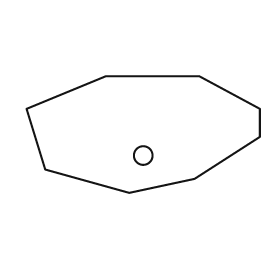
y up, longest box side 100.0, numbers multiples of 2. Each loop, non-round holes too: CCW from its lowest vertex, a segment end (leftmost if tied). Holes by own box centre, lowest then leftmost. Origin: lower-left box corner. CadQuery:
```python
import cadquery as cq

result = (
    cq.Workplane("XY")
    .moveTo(44.0, 0.0)
    .lineTo(72.0, 6.0)
    .lineTo(100.0, 24.0)
    .lineTo(100.0, 36.0)
    .lineTo(74.0, 50.0)
    .lineTo(34.0, 50.0)
    .lineTo(0.0, 36.0)
    .lineTo(8.0, 10.0)
    .close()
    .moveTo(50.0, 16.0)
    .circle(4.0)
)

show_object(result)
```